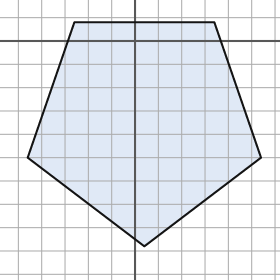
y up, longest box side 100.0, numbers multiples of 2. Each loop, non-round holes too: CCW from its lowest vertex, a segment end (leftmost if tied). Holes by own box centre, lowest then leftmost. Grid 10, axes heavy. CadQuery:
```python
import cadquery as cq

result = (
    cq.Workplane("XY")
    .moveTo(4.0, -88.0)
    .lineTo(54.0, -50.0)
    .lineTo(34.0, 8.0)
    .lineTo(-26.0, 8.0)
    .lineTo(-46.0, -50.0)
    .close()
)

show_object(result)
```